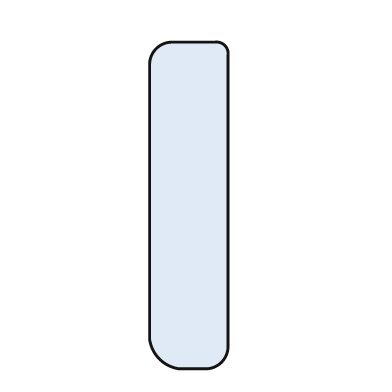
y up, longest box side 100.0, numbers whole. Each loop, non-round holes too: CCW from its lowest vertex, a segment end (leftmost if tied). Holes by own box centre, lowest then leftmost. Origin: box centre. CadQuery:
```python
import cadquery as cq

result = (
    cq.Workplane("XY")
    .moveTo(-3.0, -50.0)
    .lineTo(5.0, -50.0)
    .threePointArc((10.0, -48.0), (12.0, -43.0))
    .lineTo(12.0, 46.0)
    .threePointArc((11.0, 49.0), (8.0, 50.0))
    .lineTo(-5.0, 50.0)
    .threePointArc((-10.0, 48.0), (-12.0, 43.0))
    .lineTo(-12.0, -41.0)
    .threePointArc((-9.0, -47.0), (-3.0, -50.0))
    .close()
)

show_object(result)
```